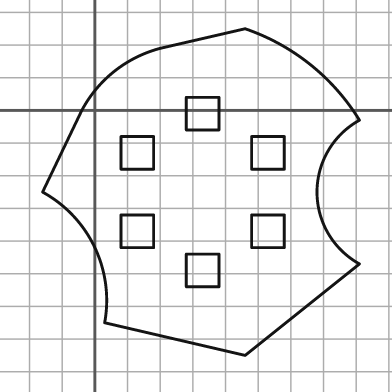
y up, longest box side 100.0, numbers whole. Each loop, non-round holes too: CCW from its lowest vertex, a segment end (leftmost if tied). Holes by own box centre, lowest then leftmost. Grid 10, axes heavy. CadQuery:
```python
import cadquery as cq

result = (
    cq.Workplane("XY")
    .moveTo(46.0, -75.0)
    .lineTo(81.0, -47.0)
    .threePointArc((68.0, -25.0), (81.0, -3.0))
    .threePointArc((66.0, 14.0), (46.0, 25.0))
    .lineTo(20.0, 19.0)
    .threePointArc((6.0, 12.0), (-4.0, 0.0))
    .lineTo(-16.0, -25.0)
    .threePointArc((0.0, -42.0), (3.0, -65.0))
    .close()
    .moveTo(28.0, -54.0)
    .lineTo(38.0, -54.0)
    .lineTo(38.0, -44.0)
    .lineTo(28.0, -44.0)
    .close()
    .moveTo(8.0, -42.0)
    .lineTo(18.0, -42.0)
    .lineTo(18.0, -32.0)
    .lineTo(8.0, -32.0)
    .close()
    .moveTo(48.0, -42.0)
    .lineTo(58.0, -42.0)
    .lineTo(58.0, -32.0)
    .lineTo(48.0, -32.0)
    .close()
    .moveTo(8.0, -18.0)
    .lineTo(18.0, -18.0)
    .lineTo(18.0, -8.0)
    .lineTo(8.0, -8.0)
    .close()
    .moveTo(48.0, -18.0)
    .lineTo(58.0, -18.0)
    .lineTo(58.0, -8.0)
    .lineTo(48.0, -8.0)
    .close()
    .moveTo(28.0, -6.0)
    .lineTo(38.0, -6.0)
    .lineTo(38.0, 4.0)
    .lineTo(28.0, 4.0)
    .close()
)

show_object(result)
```